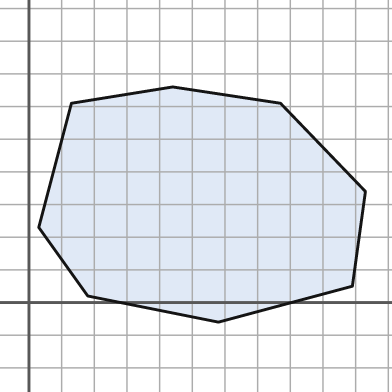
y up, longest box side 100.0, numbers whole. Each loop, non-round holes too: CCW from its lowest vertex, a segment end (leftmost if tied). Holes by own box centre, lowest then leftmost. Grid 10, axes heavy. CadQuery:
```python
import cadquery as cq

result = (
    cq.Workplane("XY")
    .moveTo(58.0, -6.0)
    .lineTo(99.0, 5.0)
    .lineTo(103.0, 34.0)
    .lineTo(77.0, 61.0)
    .lineTo(44.0, 66.0)
    .lineTo(13.0, 61.0)
    .lineTo(3.0, 23.0)
    .lineTo(18.0, 2.0)
    .close()
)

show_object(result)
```